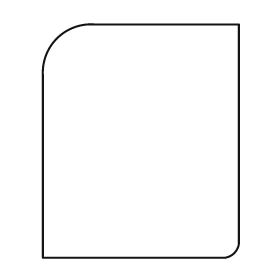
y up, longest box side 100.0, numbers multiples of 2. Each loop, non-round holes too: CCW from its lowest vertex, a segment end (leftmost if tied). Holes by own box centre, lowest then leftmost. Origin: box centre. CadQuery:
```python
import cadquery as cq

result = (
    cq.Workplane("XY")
    .moveTo(-42.0, -50.0)
    .lineTo(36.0, -50.0)
    .threePointArc((40.0, -48.0), (42.0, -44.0))
    .lineTo(42.0, 50.0)
    .lineTo(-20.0, 50.0)
    .threePointArc((-36.0, 44.0), (-42.0, 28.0))
    .close()
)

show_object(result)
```